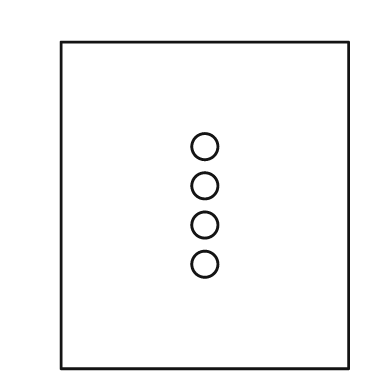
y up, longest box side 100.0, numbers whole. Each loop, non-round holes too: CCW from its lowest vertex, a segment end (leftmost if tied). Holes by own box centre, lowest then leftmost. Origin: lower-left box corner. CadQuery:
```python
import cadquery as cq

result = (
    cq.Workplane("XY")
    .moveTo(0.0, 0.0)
    .lineTo(88.0, 0.0)
    .lineTo(88.0, 100.0)
    .lineTo(0.0, 100.0)
    .close()
    .moveTo(44.0, 32.0)
    .circle(4.0)
    .moveTo(44.0, 44.0)
    .circle(4.0)
    .moveTo(44.0, 56.0)
    .circle(4.0)
    .moveTo(44.0, 68.0)
    .circle(4.0)
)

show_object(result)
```